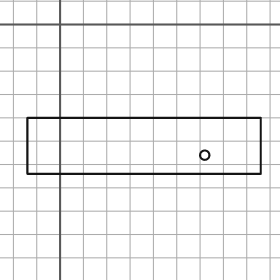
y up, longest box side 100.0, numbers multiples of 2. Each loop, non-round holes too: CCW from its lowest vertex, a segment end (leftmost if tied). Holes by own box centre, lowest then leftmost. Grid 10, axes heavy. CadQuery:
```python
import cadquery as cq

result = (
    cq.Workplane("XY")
    .moveTo(-14.0, -64.0)
    .lineTo(86.0, -64.0)
    .lineTo(86.0, -40.0)
    .lineTo(-14.0, -40.0)
    .close()
    .moveTo(62.0, -56.0)
    .circle(2.0)
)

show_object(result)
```